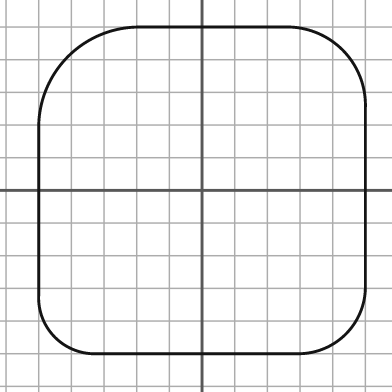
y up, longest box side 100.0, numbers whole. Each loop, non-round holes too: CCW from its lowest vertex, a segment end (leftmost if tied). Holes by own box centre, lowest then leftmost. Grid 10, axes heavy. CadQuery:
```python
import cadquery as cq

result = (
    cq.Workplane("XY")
    .moveTo(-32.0, -50.0)
    .lineTo(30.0, -50.0)
    .threePointArc((44.0, -44.0), (50.0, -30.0))
    .lineTo(50.0, 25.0)
    .threePointArc((43.0, 43.0), (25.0, 50.0))
    .lineTo(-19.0, 50.0)
    .threePointArc((-41.0, 41.0), (-50.0, 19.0))
    .lineTo(-50.0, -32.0)
    .threePointArc((-45.0, -45.0), (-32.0, -50.0))
    .close()
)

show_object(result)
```